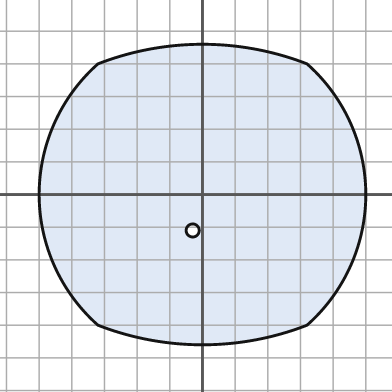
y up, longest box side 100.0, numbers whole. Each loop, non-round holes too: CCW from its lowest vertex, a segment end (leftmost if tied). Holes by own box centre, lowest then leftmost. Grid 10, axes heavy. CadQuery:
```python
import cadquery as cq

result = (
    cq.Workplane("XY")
    .moveTo(-32.0, -40.0)
    .threePointArc((0.0, -46.0), (32.0, -40.0))
    .threePointArc((50.0, 0.0), (32.0, 40.0))
    .threePointArc((0.0, 46.0), (-32.0, 40.0))
    .threePointArc((-50.0, 0.0), (-32.0, -40.0))
    .close()
    .moveTo(-3.0, -11.0)
    .circle(2.0)
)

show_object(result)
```